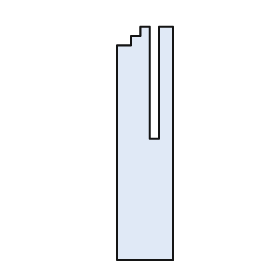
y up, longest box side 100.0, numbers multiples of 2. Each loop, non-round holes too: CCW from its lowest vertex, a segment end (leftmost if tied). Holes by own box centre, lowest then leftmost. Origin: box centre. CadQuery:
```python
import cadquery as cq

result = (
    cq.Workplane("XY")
    .moveTo(-12.0, -50.0)
    .lineTo(12.0, -50.0)
    .lineTo(12.0, 50.0)
    .lineTo(6.0, 50.0)
    .lineTo(6.0, 2.0)
    .lineTo(2.0, 2.0)
    .lineTo(2.0, 50.0)
    .lineTo(-2.0, 50.0)
    .lineTo(-2.0, 46.0)
    .lineTo(-6.0, 46.0)
    .lineTo(-6.0, 42.0)
    .lineTo(-12.0, 42.0)
    .close()
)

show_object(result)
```